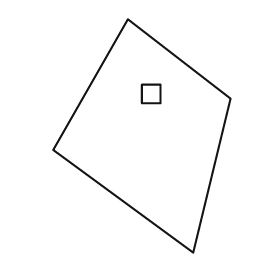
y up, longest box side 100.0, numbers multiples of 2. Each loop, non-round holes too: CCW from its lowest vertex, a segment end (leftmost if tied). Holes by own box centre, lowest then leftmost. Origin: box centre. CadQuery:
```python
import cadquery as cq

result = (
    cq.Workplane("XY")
    .moveTo(22.0, -50.0)
    .lineTo(38.0, 16.0)
    .lineTo(-6.0, 50.0)
    .lineTo(-38.0, -6.0)
    .close()
    .moveTo(0.0, 14.0)
    .lineTo(8.0, 14.0)
    .lineTo(8.0, 22.0)
    .lineTo(0.0, 22.0)
    .close()
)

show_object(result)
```